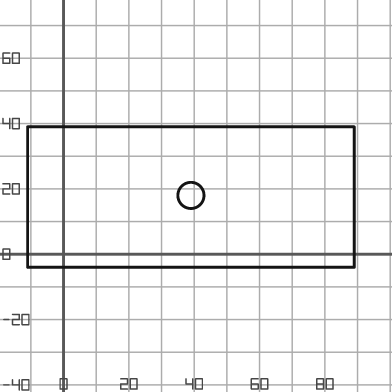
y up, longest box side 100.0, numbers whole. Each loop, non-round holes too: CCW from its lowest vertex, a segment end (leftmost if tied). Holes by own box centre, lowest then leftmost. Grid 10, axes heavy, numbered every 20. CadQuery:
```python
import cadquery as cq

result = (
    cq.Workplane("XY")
    .moveTo(-11.0, -4.0)
    .lineTo(89.0, -4.0)
    .lineTo(89.0, 39.0)
    .lineTo(-11.0, 39.0)
    .close()
    .moveTo(39.0, 18.0)
    .circle(4.0)
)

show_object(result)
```